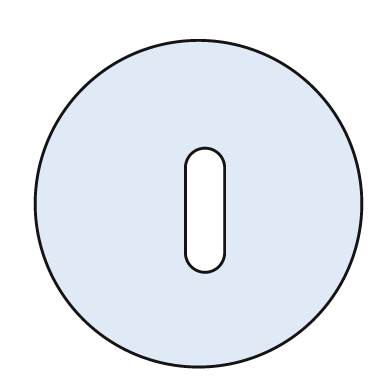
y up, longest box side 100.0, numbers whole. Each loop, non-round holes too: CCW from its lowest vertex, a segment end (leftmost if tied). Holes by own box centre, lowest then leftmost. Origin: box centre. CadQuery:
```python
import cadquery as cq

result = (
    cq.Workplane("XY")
    .moveTo(0.0, 0.0)
    .circle(50.0)
    .moveTo(-4.0, -15.0)
    .threePointArc((2.0, -21.0), (8.0, -15.0))
    .lineTo(8.0, 11.0)
    .threePointArc((2.0, 17.0), (-4.0, 11.0))
    .close()
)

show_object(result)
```